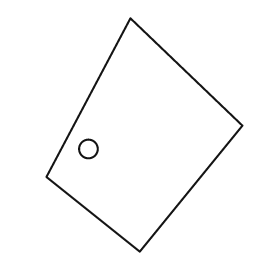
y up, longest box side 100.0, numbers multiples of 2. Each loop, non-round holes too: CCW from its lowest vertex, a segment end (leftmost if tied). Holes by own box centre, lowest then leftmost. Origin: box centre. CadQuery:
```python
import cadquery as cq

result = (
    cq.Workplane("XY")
    .moveTo(-2.0, -50.0)
    .lineTo(42.0, 4.0)
    .lineTo(-6.0, 50.0)
    .lineTo(-42.0, -18.0)
    .close()
    .moveTo(-24.0, -6.0)
    .circle(4.0)
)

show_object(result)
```